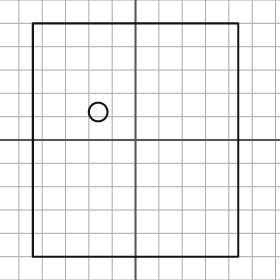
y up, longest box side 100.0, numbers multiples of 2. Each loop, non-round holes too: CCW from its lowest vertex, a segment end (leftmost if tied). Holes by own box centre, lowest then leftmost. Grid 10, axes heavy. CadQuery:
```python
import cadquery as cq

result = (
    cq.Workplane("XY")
    .moveTo(-44.0, -50.0)
    .lineTo(44.0, -50.0)
    .lineTo(44.0, 50.0)
    .lineTo(-44.0, 50.0)
    .close()
    .moveTo(-16.0, 12.0)
    .circle(4.0)
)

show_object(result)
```